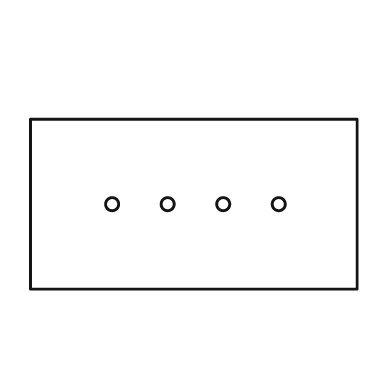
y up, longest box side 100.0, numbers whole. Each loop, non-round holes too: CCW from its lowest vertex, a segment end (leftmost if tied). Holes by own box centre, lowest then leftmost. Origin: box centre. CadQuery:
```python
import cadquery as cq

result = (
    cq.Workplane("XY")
    .moveTo(-50.0, -26.0)
    .lineTo(50.0, -26.0)
    .lineTo(50.0, 26.0)
    .lineTo(-50.0, 26.0)
    .close()
    .moveTo(-25.0, 0.0)
    .circle(2.0)
    .moveTo(-8.0, 0.0)
    .circle(2.0)
    .moveTo(9.0, 0.0)
    .circle(2.0)
    .moveTo(26.0, 0.0)
    .circle(2.0)
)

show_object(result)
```